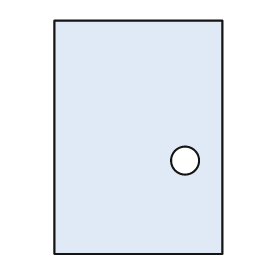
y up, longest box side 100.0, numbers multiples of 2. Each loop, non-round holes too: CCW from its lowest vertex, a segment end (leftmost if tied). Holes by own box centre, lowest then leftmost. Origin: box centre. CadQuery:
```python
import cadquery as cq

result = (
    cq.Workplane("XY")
    .moveTo(-36.0, -50.0)
    .lineTo(36.0, -50.0)
    .lineTo(36.0, 50.0)
    .lineTo(-36.0, 50.0)
    .close()
    .moveTo(20.0, -10.0)
    .circle(6.0)
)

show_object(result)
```